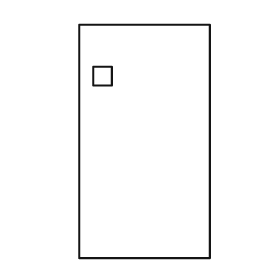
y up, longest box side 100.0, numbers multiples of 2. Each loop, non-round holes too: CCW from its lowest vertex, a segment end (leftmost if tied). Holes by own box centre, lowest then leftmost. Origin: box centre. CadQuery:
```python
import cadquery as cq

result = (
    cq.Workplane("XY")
    .moveTo(-28.0, -50.0)
    .lineTo(28.0, -50.0)
    .lineTo(28.0, 50.0)
    .lineTo(-28.0, 50.0)
    .close()
    .moveTo(-22.0, 24.0)
    .lineTo(-14.0, 24.0)
    .lineTo(-14.0, 32.0)
    .lineTo(-22.0, 32.0)
    .close()
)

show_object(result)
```